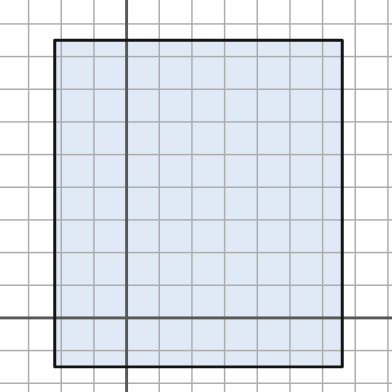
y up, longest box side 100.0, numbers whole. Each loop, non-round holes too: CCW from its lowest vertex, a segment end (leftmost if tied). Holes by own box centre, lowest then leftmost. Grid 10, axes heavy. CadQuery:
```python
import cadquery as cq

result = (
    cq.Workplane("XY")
    .moveTo(-22.0, -15.0)
    .lineTo(66.0, -15.0)
    .lineTo(66.0, 85.0)
    .lineTo(-22.0, 85.0)
    .close()
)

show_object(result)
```